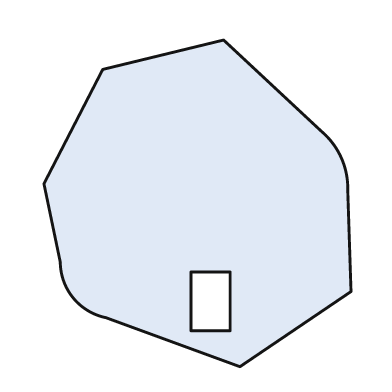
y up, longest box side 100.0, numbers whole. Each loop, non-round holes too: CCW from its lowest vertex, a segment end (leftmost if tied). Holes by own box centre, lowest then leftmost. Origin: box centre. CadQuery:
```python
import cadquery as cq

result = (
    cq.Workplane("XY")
    .moveTo(13.0, -50.0)
    .lineTo(47.0, -27.0)
    .lineTo(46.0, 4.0)
    .threePointArc((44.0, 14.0), (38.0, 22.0))
    .lineTo(8.0, 50.0)
    .lineTo(-29.0, 41.0)
    .lineTo(-47.0, 6.0)
    .lineTo(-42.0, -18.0)
    .threePointArc((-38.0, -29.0), (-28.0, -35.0))
    .close()
    .moveTo(-2.0, -39.0)
    .lineTo(10.0, -39.0)
    .lineTo(10.0, -21.0)
    .lineTo(-2.0, -21.0)
    .close()
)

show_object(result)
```